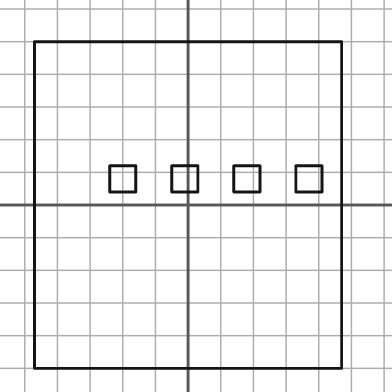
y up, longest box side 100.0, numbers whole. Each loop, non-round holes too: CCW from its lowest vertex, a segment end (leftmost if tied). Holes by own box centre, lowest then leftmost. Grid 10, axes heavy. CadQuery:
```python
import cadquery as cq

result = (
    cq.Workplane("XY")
    .moveTo(-47.0, -50.0)
    .lineTo(47.0, -50.0)
    .lineTo(47.0, 50.0)
    .lineTo(-47.0, 50.0)
    .close()
    .moveTo(-24.0, 4.0)
    .lineTo(-16.0, 4.0)
    .lineTo(-16.0, 12.0)
    .lineTo(-24.0, 12.0)
    .close()
    .moveTo(-5.0, 4.0)
    .lineTo(3.0, 4.0)
    .lineTo(3.0, 12.0)
    .lineTo(-5.0, 12.0)
    .close()
    .moveTo(14.0, 4.0)
    .lineTo(22.0, 4.0)
    .lineTo(22.0, 12.0)
    .lineTo(14.0, 12.0)
    .close()
    .moveTo(33.0, 4.0)
    .lineTo(41.0, 4.0)
    .lineTo(41.0, 12.0)
    .lineTo(33.0, 12.0)
    .close()
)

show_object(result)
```